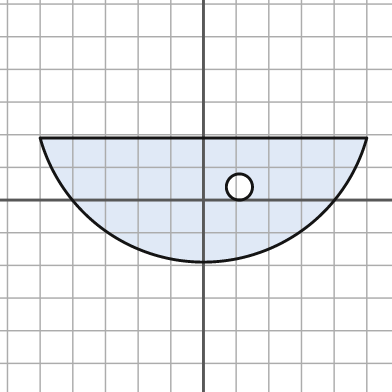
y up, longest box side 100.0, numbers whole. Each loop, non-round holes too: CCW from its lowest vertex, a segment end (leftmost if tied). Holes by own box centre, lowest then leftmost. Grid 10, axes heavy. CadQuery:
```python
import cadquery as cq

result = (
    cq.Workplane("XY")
    .moveTo(-50.0, 19.0)
    .threePointArc((0.0, -19.0), (50.0, 19.0))
    .close()
    .moveTo(11.0, 4.0)
    .circle(4.0)
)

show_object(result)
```